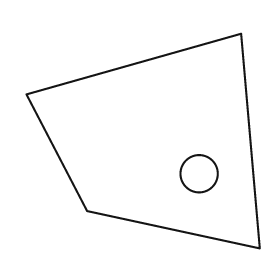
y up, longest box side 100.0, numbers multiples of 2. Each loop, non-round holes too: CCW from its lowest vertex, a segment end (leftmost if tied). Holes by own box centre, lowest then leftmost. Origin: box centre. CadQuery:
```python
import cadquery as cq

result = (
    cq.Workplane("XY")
    .moveTo(50.0, -46.0)
    .lineTo(42.0, 46.0)
    .lineTo(-50.0, 20.0)
    .lineTo(-24.0, -30.0)
    .close()
    .moveTo(24.0, -14.0)
    .circle(8.0)
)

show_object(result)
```